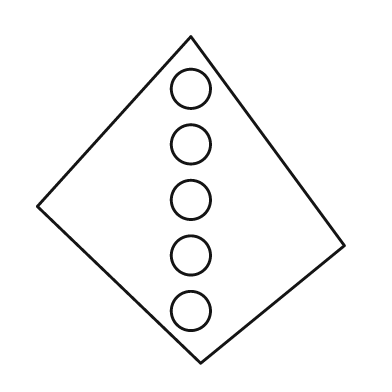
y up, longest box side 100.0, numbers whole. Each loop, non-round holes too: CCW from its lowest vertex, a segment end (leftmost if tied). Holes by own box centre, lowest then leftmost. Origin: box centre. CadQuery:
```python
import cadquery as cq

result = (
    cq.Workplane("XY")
    .moveTo(3.0, -50.0)
    .lineTo(47.0, -14.0)
    .lineTo(0.0, 50.0)
    .lineTo(-47.0, -2.0)
    .close()
    .moveTo(0.0, -34.0)
    .circle(6.0)
    .moveTo(0.0, -17.0)
    .circle(6.0)
    .moveTo(0.0, 0.0)
    .circle(6.0)
    .moveTo(0.0, 17.0)
    .circle(6.0)
    .moveTo(0.0, 34.0)
    .circle(6.0)
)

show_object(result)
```